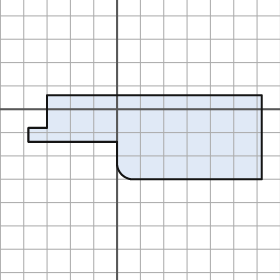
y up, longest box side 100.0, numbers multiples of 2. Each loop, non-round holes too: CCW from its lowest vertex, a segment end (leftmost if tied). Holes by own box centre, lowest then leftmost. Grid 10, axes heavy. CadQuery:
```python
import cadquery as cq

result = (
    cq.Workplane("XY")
    .moveTo(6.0, -30.0)
    .lineTo(62.0, -30.0)
    .lineTo(62.0, 6.0)
    .lineTo(-30.0, 6.0)
    .lineTo(-30.0, -8.0)
    .lineTo(-38.0, -8.0)
    .lineTo(-38.0, -14.0)
    .lineTo(0.0, -14.0)
    .lineTo(0.0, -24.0)
    .threePointArc((2.0, -28.0), (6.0, -30.0))
    .close()
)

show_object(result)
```